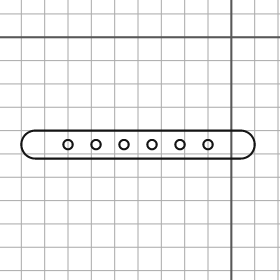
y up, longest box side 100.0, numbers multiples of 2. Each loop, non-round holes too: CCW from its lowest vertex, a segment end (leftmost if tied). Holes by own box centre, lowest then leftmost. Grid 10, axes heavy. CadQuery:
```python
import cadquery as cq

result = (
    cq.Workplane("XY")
    .moveTo(-84.0, -52.0)
    .lineTo(4.0, -52.0)
    .threePointArc((10.0, -46.0), (4.0, -40.0))
    .lineTo(-84.0, -40.0)
    .threePointArc((-90.0, -46.0), (-84.0, -52.0))
    .close()
    .moveTo(-70.0, -46.0)
    .circle(2.0)
    .moveTo(-58.0, -46.0)
    .circle(2.0)
    .moveTo(-46.0, -46.0)
    .circle(2.0)
    .moveTo(-34.0, -46.0)
    .circle(2.0)
    .moveTo(-22.0, -46.0)
    .circle(2.0)
    .moveTo(-10.0, -46.0)
    .circle(2.0)
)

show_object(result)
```